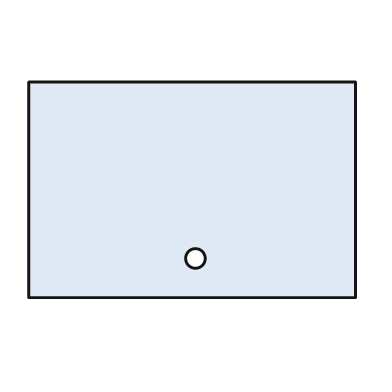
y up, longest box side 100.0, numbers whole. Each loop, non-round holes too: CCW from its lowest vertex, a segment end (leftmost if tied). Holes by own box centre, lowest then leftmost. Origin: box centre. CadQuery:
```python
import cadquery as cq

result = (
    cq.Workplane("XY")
    .moveTo(-50.0, -33.0)
    .lineTo(50.0, -33.0)
    .lineTo(50.0, 33.0)
    .lineTo(-50.0, 33.0)
    .close()
    .moveTo(1.0, -21.0)
    .circle(3.0)
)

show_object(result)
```